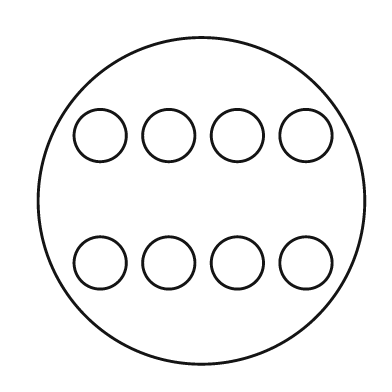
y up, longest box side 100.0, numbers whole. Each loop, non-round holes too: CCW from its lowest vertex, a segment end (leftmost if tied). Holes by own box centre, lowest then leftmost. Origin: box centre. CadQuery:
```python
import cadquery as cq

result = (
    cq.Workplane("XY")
    .moveTo(0.0, 0.0)
    .circle(50.0)
    .moveTo(-31.0, -19.0)
    .circle(8.0)
    .moveTo(-10.0, -19.0)
    .circle(8.0)
    .moveTo(11.0, -19.0)
    .circle(8.0)
    .moveTo(32.0, -19.0)
    .circle(8.0)
    .moveTo(-31.0, 20.0)
    .circle(8.0)
    .moveTo(-10.0, 20.0)
    .circle(8.0)
    .moveTo(11.0, 20.0)
    .circle(8.0)
    .moveTo(32.0, 20.0)
    .circle(8.0)
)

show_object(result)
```